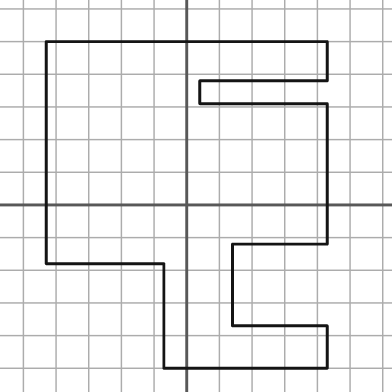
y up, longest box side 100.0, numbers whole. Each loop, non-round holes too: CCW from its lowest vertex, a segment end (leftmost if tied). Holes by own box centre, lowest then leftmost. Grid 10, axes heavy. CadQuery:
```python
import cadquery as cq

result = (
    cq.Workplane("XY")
    .moveTo(-7.0, -50.0)
    .lineTo(43.0, -50.0)
    .lineTo(43.0, -37.0)
    .lineTo(14.0, -37.0)
    .lineTo(14.0, -12.0)
    .lineTo(43.0, -12.0)
    .lineTo(43.0, 31.0)
    .lineTo(4.0, 31.0)
    .lineTo(4.0, 38.0)
    .lineTo(43.0, 38.0)
    .lineTo(43.0, 50.0)
    .lineTo(-43.0, 50.0)
    .lineTo(-43.0, -18.0)
    .lineTo(-7.0, -18.0)
    .close()
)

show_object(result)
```